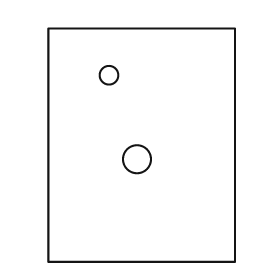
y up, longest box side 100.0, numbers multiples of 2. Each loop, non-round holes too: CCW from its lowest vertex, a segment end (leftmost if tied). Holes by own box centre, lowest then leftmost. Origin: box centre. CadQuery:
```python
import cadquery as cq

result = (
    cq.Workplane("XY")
    .moveTo(-40.0, -50.0)
    .lineTo(40.0, -50.0)
    .lineTo(40.0, 50.0)
    .lineTo(-40.0, 50.0)
    .close()
    .moveTo(-2.0, -6.0)
    .circle(6.0)
    .moveTo(-14.0, 30.0)
    .circle(4.0)
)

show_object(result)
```